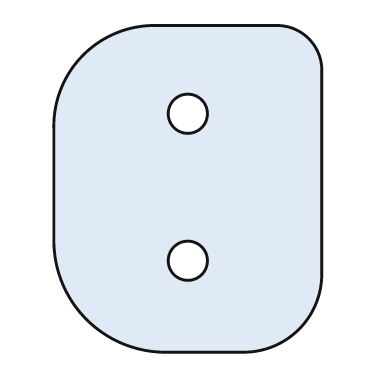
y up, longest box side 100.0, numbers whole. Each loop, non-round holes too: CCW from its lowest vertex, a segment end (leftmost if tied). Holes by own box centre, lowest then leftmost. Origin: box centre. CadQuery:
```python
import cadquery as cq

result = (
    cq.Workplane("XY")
    .moveTo(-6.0, -50.0)
    .lineTo(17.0, -50.0)
    .threePointArc((34.0, -43.0), (41.0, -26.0))
    .lineTo(41.0, 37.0)
    .threePointArc((37.0, 46.0), (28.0, 50.0))
    .lineTo(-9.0, 50.0)
    .threePointArc((-32.0, 41.0), (-41.0, 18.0))
    .lineTo(-41.0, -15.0)
    .threePointArc((-31.0, -40.0), (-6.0, -50.0))
    .close()
    .moveTo(0.0, -22.0)
    .circle(6.0)
    .moveTo(0.0, 23.0)
    .circle(6.0)
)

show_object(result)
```